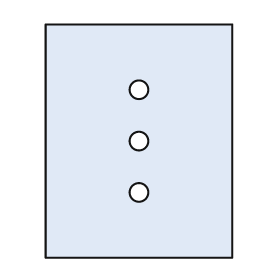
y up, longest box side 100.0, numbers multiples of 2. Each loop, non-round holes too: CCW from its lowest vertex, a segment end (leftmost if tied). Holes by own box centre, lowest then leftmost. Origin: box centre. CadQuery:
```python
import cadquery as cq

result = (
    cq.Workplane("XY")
    .moveTo(-40.0, -50.0)
    .lineTo(40.0, -50.0)
    .lineTo(40.0, 50.0)
    .lineTo(-40.0, 50.0)
    .close()
    .moveTo(0.0, -22.0)
    .circle(4.0)
    .moveTo(0.0, 0.0)
    .circle(4.0)
    .moveTo(0.0, 22.0)
    .circle(4.0)
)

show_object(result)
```